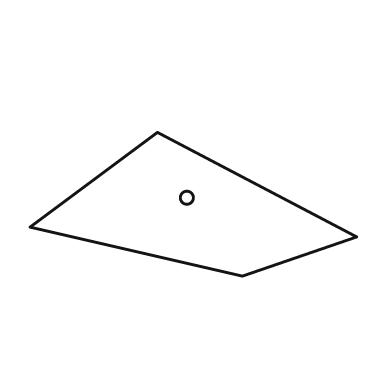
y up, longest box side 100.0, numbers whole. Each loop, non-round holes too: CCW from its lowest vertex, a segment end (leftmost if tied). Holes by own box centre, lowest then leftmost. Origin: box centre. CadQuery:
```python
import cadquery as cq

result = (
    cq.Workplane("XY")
    .moveTo(15.0, -22.0)
    .lineTo(50.0, -10.0)
    .lineTo(-11.0, 22.0)
    .lineTo(-50.0, -7.0)
    .close()
    .moveTo(-2.0, 2.0)
    .circle(2.0)
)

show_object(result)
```